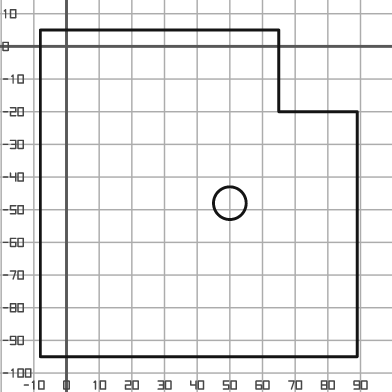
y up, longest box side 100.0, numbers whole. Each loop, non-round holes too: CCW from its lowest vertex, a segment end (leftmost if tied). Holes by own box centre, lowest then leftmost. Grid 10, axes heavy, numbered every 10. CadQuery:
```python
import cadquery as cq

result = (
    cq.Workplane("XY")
    .moveTo(-8.0, -95.0)
    .lineTo(89.0, -95.0)
    .lineTo(89.0, -20.0)
    .lineTo(65.0, -20.0)
    .lineTo(65.0, 5.0)
    .lineTo(-8.0, 5.0)
    .close()
    .moveTo(50.0, -48.0)
    .circle(5.0)
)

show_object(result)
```